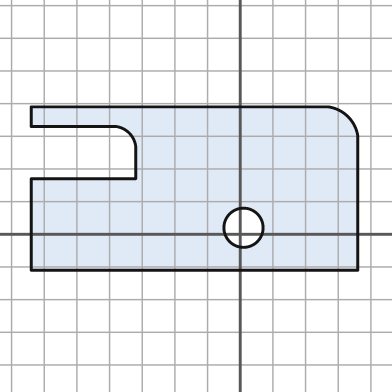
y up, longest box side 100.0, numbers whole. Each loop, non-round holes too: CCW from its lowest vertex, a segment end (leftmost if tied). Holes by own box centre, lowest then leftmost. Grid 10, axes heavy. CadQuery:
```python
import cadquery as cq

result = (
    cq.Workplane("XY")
    .moveTo(-64.0, -11.0)
    .lineTo(36.0, -11.0)
    .lineTo(36.0, 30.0)
    .threePointArc((33.0, 36.0), (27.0, 39.0))
    .lineTo(-64.0, 39.0)
    .lineTo(-64.0, 33.0)
    .lineTo(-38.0, 33.0)
    .threePointArc((-34.0, 31.0), (-32.0, 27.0))
    .lineTo(-32.0, 17.0)
    .lineTo(-64.0, 17.0)
    .close()
    .moveTo(1.0, 2.0)
    .circle(6.0)
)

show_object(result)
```